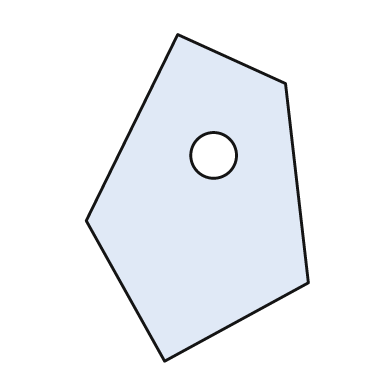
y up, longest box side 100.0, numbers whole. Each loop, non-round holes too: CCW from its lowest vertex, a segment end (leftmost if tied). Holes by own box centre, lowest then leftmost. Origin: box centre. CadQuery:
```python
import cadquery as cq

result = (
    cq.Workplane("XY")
    .moveTo(-10.0, -50.0)
    .lineTo(34.0, -26.0)
    .lineTo(27.0, 35.0)
    .lineTo(-6.0, 50.0)
    .lineTo(-34.0, -7.0)
    .close()
    .moveTo(5.0, 13.0)
    .circle(7.0)
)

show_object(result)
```